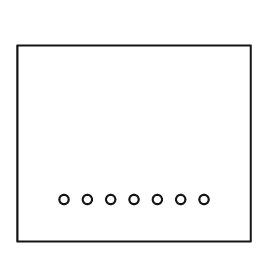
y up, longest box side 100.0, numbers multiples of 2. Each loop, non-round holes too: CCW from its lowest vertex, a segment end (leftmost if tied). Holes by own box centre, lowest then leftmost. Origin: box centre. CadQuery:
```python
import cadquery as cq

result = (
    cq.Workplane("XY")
    .moveTo(-50.0, -42.0)
    .lineTo(50.0, -42.0)
    .lineTo(50.0, 42.0)
    .lineTo(-50.0, 42.0)
    .close()
    .moveTo(-30.0, -24.0)
    .circle(2.0)
    .moveTo(-20.0, -24.0)
    .circle(2.0)
    .moveTo(-10.0, -24.0)
    .circle(2.0)
    .moveTo(0.0, -24.0)
    .circle(2.0)
    .moveTo(10.0, -24.0)
    .circle(2.0)
    .moveTo(20.0, -24.0)
    .circle(2.0)
    .moveTo(30.0, -24.0)
    .circle(2.0)
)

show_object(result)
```